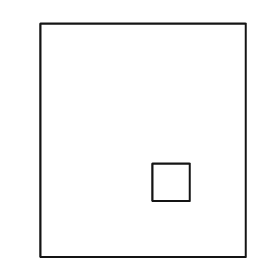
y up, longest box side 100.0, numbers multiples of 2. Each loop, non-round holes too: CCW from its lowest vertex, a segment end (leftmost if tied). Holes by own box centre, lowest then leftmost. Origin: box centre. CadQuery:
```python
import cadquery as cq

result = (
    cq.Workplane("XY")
    .moveTo(-44.0, -50.0)
    .lineTo(44.0, -50.0)
    .lineTo(44.0, 50.0)
    .lineTo(-44.0, 50.0)
    .close()
    .moveTo(4.0, -26.0)
    .lineTo(20.0, -26.0)
    .lineTo(20.0, -10.0)
    .lineTo(4.0, -10.0)
    .close()
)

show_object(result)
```